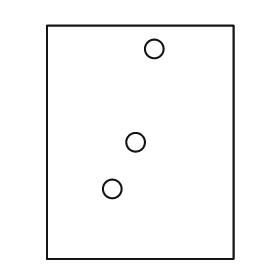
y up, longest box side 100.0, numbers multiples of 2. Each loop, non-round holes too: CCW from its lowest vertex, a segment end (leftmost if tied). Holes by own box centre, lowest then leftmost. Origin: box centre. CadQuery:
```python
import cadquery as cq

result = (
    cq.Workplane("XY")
    .moveTo(-40.0, -50.0)
    .lineTo(40.0, -50.0)
    .lineTo(40.0, 50.0)
    .lineTo(-40.0, 50.0)
    .close()
    .moveTo(-12.0, -20.0)
    .circle(4.0)
    .moveTo(-2.0, 0.0)
    .circle(4.0)
    .moveTo(6.0, 40.0)
    .circle(4.0)
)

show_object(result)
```